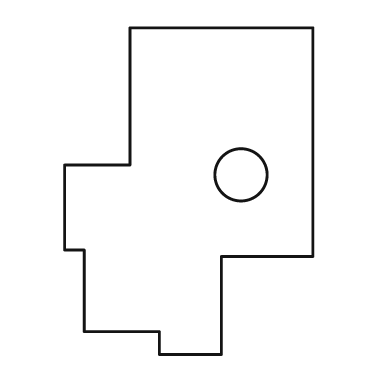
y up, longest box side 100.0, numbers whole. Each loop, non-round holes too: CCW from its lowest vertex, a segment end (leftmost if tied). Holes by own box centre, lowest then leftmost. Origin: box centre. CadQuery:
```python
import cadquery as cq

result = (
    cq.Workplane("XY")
    .moveTo(-9.0, -50.0)
    .lineTo(10.0, -50.0)
    .lineTo(10.0, -20.0)
    .lineTo(38.0, -20.0)
    .lineTo(38.0, 50.0)
    .lineTo(-18.0, 50.0)
    .lineTo(-18.0, 8.0)
    .lineTo(-38.0, 8.0)
    .lineTo(-38.0, -18.0)
    .lineTo(-32.0, -18.0)
    .lineTo(-32.0, -43.0)
    .lineTo(-9.0, -43.0)
    .close()
    .moveTo(16.0, 5.0)
    .circle(8.0)
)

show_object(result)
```